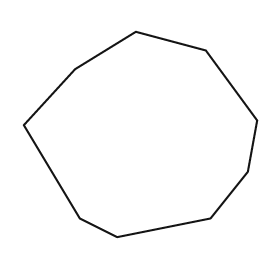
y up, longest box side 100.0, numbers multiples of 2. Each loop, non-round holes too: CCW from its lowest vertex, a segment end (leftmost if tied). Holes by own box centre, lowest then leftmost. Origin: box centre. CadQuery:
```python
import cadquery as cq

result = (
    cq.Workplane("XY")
    .moveTo(-10.0, -44.0)
    .lineTo(30.0, -36.0)
    .lineTo(46.0, -16.0)
    .lineTo(50.0, 6.0)
    .lineTo(28.0, 36.0)
    .lineTo(-2.0, 44.0)
    .lineTo(-28.0, 28.0)
    .lineTo(-50.0, 4.0)
    .lineTo(-26.0, -36.0)
    .close()
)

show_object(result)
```